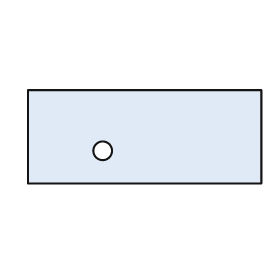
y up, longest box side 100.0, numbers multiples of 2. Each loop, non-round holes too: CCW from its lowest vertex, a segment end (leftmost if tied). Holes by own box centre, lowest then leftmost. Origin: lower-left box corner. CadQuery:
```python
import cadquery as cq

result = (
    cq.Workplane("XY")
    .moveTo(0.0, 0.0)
    .lineTo(100.0, 0.0)
    .lineTo(100.0, 40.0)
    .lineTo(0.0, 40.0)
    .close()
    .moveTo(32.0, 14.0)
    .circle(4.0)
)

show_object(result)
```